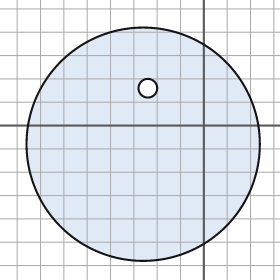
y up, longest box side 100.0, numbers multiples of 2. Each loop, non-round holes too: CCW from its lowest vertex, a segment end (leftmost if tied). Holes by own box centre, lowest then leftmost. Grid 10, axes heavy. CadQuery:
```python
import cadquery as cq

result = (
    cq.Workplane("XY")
    .moveTo(-26.0, -8.0)
    .circle(50.0)
    .moveTo(-24.0, 16.0)
    .circle(4.0)
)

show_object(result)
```